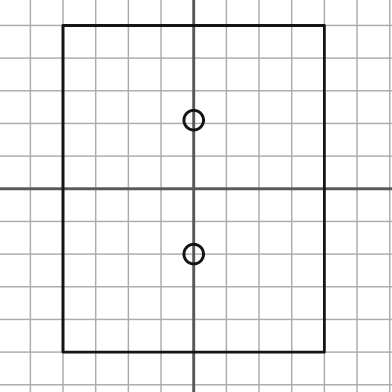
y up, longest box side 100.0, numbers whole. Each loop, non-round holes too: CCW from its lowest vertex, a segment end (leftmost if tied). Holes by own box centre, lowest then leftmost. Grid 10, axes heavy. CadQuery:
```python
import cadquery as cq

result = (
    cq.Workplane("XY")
    .moveTo(-40.0, -50.0)
    .lineTo(40.0, -50.0)
    .lineTo(40.0, 50.0)
    .lineTo(-40.0, 50.0)
    .close()
    .moveTo(0.0, -20.0)
    .circle(3.0)
    .moveTo(0.0, 21.0)
    .circle(3.0)
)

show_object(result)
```